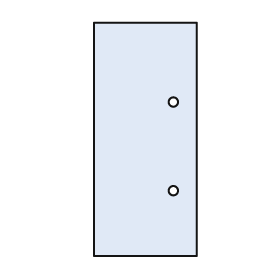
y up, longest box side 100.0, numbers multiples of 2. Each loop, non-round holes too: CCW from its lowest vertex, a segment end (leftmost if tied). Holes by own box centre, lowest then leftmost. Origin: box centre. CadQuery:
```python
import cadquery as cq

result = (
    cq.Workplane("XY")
    .moveTo(-22.0, -50.0)
    .lineTo(22.0, -50.0)
    .lineTo(22.0, 50.0)
    .lineTo(-22.0, 50.0)
    .close()
    .moveTo(12.0, -22.0)
    .circle(2.0)
    .moveTo(12.0, 16.0)
    .circle(2.0)
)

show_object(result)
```